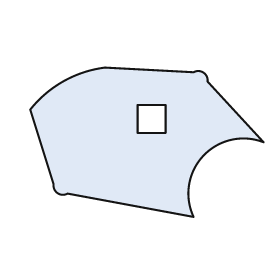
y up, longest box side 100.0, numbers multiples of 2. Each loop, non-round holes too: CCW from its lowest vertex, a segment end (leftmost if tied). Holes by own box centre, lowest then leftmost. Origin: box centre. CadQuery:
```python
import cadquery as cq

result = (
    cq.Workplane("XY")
    .moveTo(20.0, -32.0)
    .threePointArc((24.0, -6.0), (50.0, 0.0))
    .lineTo(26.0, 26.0)
    .threePointArc((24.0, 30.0), (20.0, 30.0))
    .lineTo(-18.0, 32.0)
    .threePointArc((-36.0, 26.0), (-50.0, 14.0))
    .lineTo(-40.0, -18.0)
    .threePointArc((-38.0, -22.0), (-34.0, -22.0))
    .close()
    .moveTo(-4.0, 4.0)
    .lineTo(8.0, 4.0)
    .lineTo(8.0, 16.0)
    .lineTo(-4.0, 16.0)
    .close()
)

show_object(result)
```